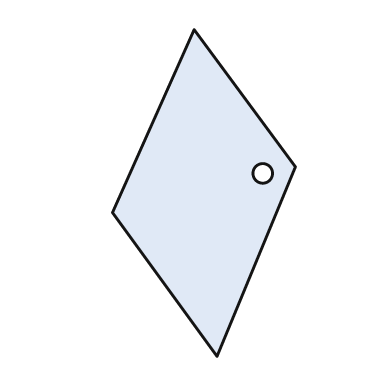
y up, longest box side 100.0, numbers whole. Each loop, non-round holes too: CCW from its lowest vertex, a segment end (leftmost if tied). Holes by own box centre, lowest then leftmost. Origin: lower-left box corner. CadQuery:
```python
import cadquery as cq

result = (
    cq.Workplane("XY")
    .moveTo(32.0, 0.0)
    .lineTo(56.0, 58.0)
    .lineTo(25.0, 100.0)
    .lineTo(0.0, 44.0)
    .close()
    .moveTo(46.0, 56.0)
    .circle(3.0)
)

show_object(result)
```